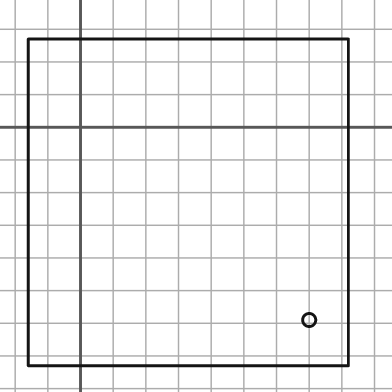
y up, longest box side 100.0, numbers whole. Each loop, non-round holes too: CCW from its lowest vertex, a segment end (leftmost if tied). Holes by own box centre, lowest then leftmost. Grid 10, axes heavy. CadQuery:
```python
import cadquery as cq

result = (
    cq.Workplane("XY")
    .moveTo(-16.0, -73.0)
    .lineTo(82.0, -73.0)
    .lineTo(82.0, 27.0)
    .lineTo(-16.0, 27.0)
    .close()
    .moveTo(70.0, -59.0)
    .circle(2.0)
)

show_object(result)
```